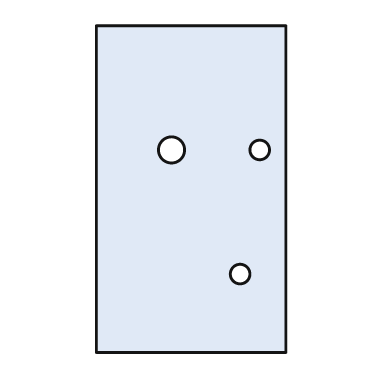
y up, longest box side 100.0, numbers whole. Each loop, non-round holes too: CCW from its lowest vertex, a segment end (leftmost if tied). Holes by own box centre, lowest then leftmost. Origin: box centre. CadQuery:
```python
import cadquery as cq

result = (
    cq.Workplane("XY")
    .moveTo(-29.0, -50.0)
    .lineTo(29.0, -50.0)
    .lineTo(29.0, 50.0)
    .lineTo(-29.0, 50.0)
    .close()
    .moveTo(15.0, -26.0)
    .circle(3.0)
    .moveTo(-6.0, 12.0)
    .circle(4.0)
    .moveTo(21.0, 12.0)
    .circle(3.0)
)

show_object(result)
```